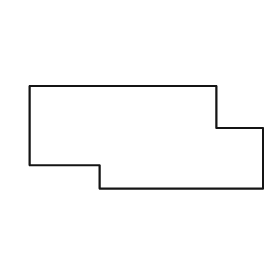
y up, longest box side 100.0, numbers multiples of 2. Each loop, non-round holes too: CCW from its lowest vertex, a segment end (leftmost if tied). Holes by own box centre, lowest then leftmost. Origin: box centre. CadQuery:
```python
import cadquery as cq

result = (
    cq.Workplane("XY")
    .moveTo(-20.0, -22.0)
    .lineTo(50.0, -22.0)
    .lineTo(50.0, 4.0)
    .lineTo(30.0, 4.0)
    .lineTo(30.0, 22.0)
    .lineTo(-50.0, 22.0)
    .lineTo(-50.0, -12.0)
    .lineTo(-20.0, -12.0)
    .close()
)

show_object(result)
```